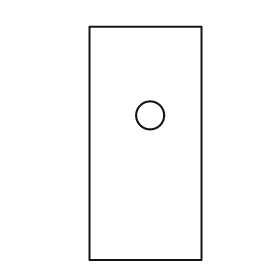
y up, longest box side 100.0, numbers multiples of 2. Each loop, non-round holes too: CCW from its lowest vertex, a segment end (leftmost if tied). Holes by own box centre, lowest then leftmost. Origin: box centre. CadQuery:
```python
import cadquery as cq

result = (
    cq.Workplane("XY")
    .moveTo(-24.0, -50.0)
    .lineTo(24.0, -50.0)
    .lineTo(24.0, 50.0)
    .lineTo(-24.0, 50.0)
    .close()
    .moveTo(2.0, 12.0)
    .circle(6.0)
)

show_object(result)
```